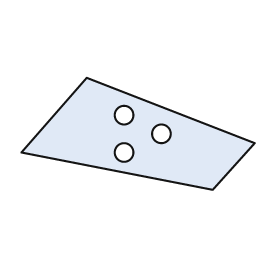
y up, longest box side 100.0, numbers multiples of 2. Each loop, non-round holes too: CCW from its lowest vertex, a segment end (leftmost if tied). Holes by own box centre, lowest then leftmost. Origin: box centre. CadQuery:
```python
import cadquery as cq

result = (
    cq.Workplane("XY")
    .moveTo(32.0, -24.0)
    .lineTo(50.0, -4.0)
    .lineTo(-22.0, 24.0)
    .lineTo(-50.0, -8.0)
    .close()
    .moveTo(-6.0, -8.0)
    .circle(4.0)
    .moveTo(10.0, 0.0)
    .circle(4.0)
    .moveTo(-6.0, 8.0)
    .circle(4.0)
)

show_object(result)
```